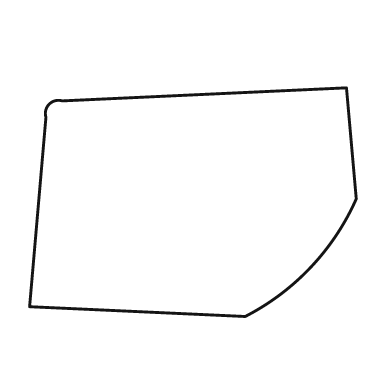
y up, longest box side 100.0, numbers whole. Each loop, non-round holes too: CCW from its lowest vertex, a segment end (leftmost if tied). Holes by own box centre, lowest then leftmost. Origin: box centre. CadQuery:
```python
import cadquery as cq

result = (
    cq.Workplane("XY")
    .moveTo(16.0, -35.0)
    .threePointArc((36.0, -20.0), (50.0, 1.0))
    .lineTo(47.0, 35.0)
    .lineTo(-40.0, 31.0)
    .threePointArc((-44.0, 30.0), (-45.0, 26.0))
    .lineTo(-50.0, -32.0)
    .close()
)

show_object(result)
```